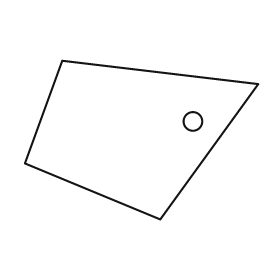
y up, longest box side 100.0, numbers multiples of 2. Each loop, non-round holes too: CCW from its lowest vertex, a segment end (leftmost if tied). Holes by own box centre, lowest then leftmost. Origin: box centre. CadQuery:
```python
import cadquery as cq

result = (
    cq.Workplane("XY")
    .moveTo(8.0, -34.0)
    .lineTo(50.0, 24.0)
    .lineTo(-34.0, 34.0)
    .lineTo(-50.0, -10.0)
    .close()
    .moveTo(22.0, 8.0)
    .circle(4.0)
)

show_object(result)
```